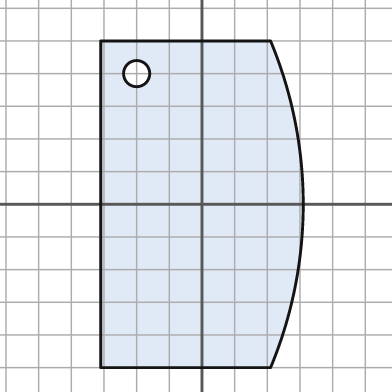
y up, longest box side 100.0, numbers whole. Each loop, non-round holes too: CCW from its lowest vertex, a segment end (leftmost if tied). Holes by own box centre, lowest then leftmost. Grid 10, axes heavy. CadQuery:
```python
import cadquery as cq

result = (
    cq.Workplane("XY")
    .moveTo(-31.0, -50.0)
    .lineTo(21.0, -50.0)
    .threePointArc((31.0, 0.0), (21.0, 50.0))
    .lineTo(-31.0, 50.0)
    .close()
    .moveTo(-20.0, 40.0)
    .circle(4.0)
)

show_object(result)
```